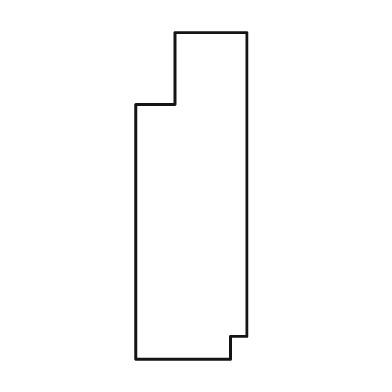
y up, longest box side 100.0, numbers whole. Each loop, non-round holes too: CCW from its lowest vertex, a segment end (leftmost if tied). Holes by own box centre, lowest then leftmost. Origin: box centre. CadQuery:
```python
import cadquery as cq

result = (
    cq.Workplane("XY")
    .moveTo(-17.0, -50.0)
    .lineTo(12.0, -50.0)
    .lineTo(12.0, -43.0)
    .lineTo(17.0, -43.0)
    .lineTo(17.0, 50.0)
    .lineTo(-5.0, 50.0)
    .lineTo(-5.0, 28.0)
    .lineTo(-17.0, 28.0)
    .close()
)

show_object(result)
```